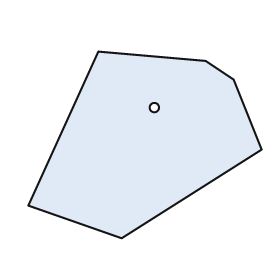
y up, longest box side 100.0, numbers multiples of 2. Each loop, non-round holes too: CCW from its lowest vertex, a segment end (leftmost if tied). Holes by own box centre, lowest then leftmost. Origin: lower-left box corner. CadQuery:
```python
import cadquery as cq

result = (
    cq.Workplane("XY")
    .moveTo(40.0, 0.0)
    .lineTo(100.0, 38.0)
    .lineTo(88.0, 68.0)
    .lineTo(76.0, 76.0)
    .lineTo(30.0, 80.0)
    .lineTo(0.0, 14.0)
    .close()
    .moveTo(54.0, 56.0)
    .circle(2.0)
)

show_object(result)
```